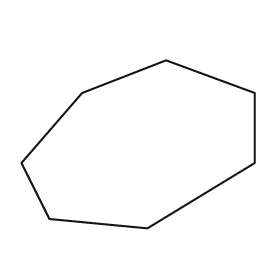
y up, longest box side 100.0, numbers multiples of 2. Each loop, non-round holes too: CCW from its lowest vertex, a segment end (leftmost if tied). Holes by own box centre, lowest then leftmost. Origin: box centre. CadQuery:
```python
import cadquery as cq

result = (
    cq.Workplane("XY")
    .moveTo(4.0, -36.0)
    .lineTo(50.0, -8.0)
    .lineTo(50.0, 22.0)
    .lineTo(12.0, 36.0)
    .lineTo(-24.0, 22.0)
    .lineTo(-50.0, -8.0)
    .lineTo(-38.0, -32.0)
    .close()
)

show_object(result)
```